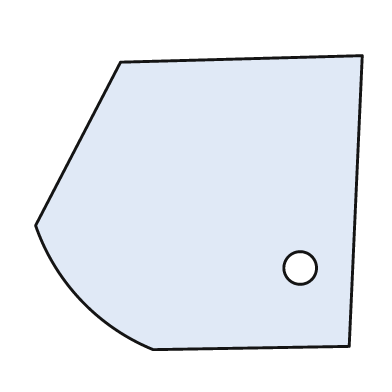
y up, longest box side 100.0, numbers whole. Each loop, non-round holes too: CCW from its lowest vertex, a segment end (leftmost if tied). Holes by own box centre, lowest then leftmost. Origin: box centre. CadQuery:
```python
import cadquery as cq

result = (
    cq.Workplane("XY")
    .moveTo(-14.0, -45.0)
    .lineTo(46.0, -44.0)
    .lineTo(50.0, 45.0)
    .lineTo(-24.0, 43.0)
    .lineTo(-50.0, -7.0)
    .threePointArc((-36.0, -30.0), (-14.0, -45.0))
    .close()
    .moveTo(31.0, -20.0)
    .circle(5.0)
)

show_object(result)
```